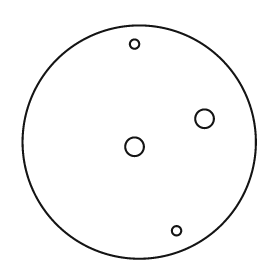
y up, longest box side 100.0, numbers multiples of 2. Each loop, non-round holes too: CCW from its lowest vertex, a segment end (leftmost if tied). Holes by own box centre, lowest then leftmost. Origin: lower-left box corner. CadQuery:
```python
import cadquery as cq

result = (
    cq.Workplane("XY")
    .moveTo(50.0, 50.0)
    .circle(50.0)
    .moveTo(66.0, 12.0)
    .circle(2.0)
    .moveTo(48.0, 48.0)
    .circle(4.0)
    .moveTo(78.0, 60.0)
    .circle(4.0)
    .moveTo(48.0, 92.0)
    .circle(2.0)
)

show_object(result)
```